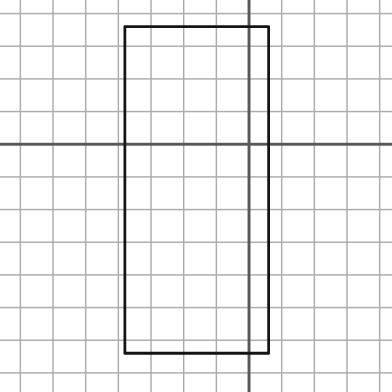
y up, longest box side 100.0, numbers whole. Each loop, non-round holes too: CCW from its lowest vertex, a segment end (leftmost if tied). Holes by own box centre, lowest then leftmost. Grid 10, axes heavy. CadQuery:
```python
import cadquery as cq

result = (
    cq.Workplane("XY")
    .moveTo(-38.0, -64.0)
    .lineTo(6.0, -64.0)
    .lineTo(6.0, 36.0)
    .lineTo(-38.0, 36.0)
    .close()
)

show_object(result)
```